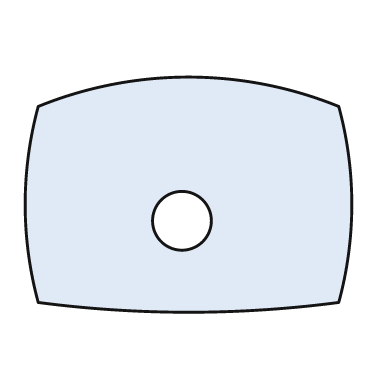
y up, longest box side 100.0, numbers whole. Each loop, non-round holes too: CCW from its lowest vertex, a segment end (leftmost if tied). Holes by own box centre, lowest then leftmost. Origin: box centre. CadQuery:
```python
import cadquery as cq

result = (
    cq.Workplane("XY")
    .moveTo(-46.0, -33.0)
    .threePointArc((0.0, -36.0), (46.0, -33.0))
    .threePointArc((50.0, -3.0), (46.0, 27.0))
    .threePointArc((0.0, 36.0), (-46.0, 27.0))
    .threePointArc((-50.0, -3.0), (-46.0, -33.0))
    .close()
    .moveTo(-2.0, -8.0)
    .circle(9.0)
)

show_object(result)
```